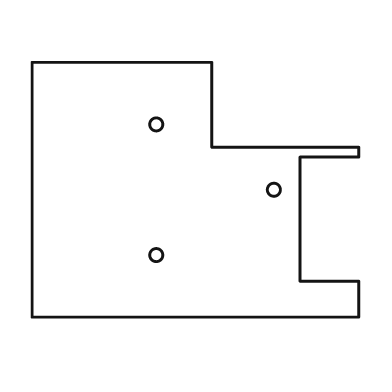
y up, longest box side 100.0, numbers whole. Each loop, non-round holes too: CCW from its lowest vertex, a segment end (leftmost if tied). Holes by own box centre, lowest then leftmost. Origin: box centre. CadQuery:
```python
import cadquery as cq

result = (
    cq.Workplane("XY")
    .moveTo(-50.0, -39.0)
    .lineTo(50.0, -39.0)
    .lineTo(50.0, -28.0)
    .lineTo(32.0, -28.0)
    .lineTo(32.0, 10.0)
    .lineTo(50.0, 10.0)
    .lineTo(50.0, 13.0)
    .lineTo(5.0, 13.0)
    .lineTo(5.0, 39.0)
    .lineTo(-50.0, 39.0)
    .close()
    .moveTo(-12.0, -20.0)
    .circle(2.0)
    .moveTo(24.0, 0.0)
    .circle(2.0)
    .moveTo(-12.0, 20.0)
    .circle(2.0)
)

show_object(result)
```